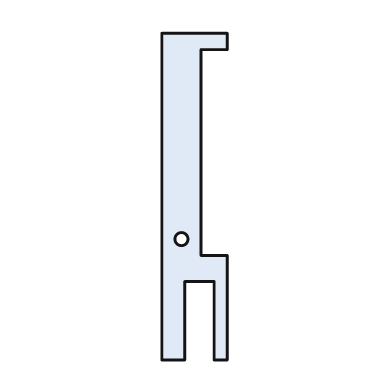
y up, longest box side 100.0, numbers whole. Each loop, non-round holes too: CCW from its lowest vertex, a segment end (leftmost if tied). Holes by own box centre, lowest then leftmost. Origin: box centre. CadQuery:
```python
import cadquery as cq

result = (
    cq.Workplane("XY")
    .moveTo(-10.0, -50.0)
    .lineTo(-3.0, -50.0)
    .lineTo(-3.0, -26.0)
    .lineTo(6.0, -26.0)
    .lineTo(6.0, -50.0)
    .lineTo(10.0, -50.0)
    .lineTo(10.0, -18.0)
    .lineTo(2.0, -18.0)
    .lineTo(2.0, 45.0)
    .lineTo(10.0, 45.0)
    .lineTo(10.0, 50.0)
    .lineTo(-10.0, 50.0)
    .close()
    .moveTo(-4.0, -13.0)
    .circle(2.0)
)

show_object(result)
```